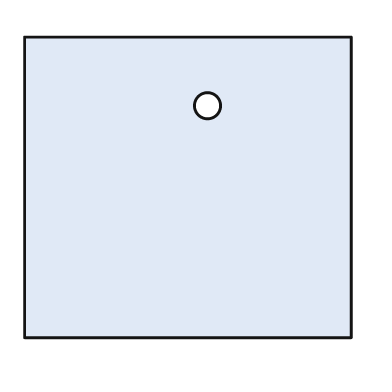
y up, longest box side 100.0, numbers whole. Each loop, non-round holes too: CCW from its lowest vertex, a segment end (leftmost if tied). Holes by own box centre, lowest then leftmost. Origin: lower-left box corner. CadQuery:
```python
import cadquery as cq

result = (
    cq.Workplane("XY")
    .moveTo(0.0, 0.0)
    .lineTo(100.0, 0.0)
    .lineTo(100.0, 92.0)
    .lineTo(0.0, 92.0)
    .close()
    .moveTo(56.0, 71.0)
    .circle(4.0)
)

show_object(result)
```